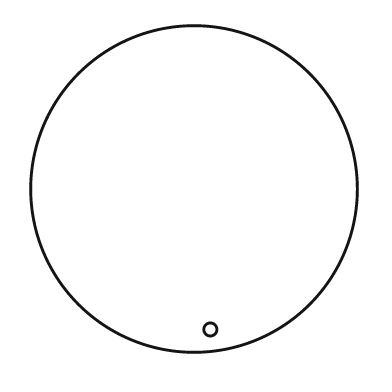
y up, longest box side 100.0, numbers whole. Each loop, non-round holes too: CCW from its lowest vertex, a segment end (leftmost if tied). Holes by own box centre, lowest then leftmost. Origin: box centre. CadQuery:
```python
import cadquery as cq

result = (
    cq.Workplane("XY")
    .moveTo(0.0, 0.0)
    .circle(50.0)
    .moveTo(5.0, -43.0)
    .circle(2.0)
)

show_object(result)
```